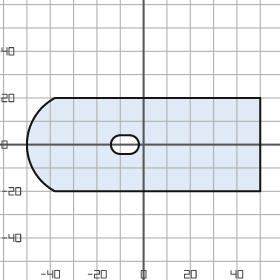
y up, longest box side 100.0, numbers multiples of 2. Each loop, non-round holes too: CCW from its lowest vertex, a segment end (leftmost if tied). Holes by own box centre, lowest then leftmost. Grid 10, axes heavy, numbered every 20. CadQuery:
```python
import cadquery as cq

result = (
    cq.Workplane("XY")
    .moveTo(-38.0, -20.0)
    .lineTo(50.0, -20.0)
    .lineTo(50.0, 20.0)
    .lineTo(-38.0, 20.0)
    .threePointArc((-50.0, 0.0), (-38.0, -20.0))
    .close()
    .moveTo(-10.0, -4.0)
    .lineTo(-6.0, -4.0)
    .threePointArc((-2.0, 0.0), (-6.0, 4.0))
    .lineTo(-10.0, 4.0)
    .threePointArc((-14.0, 0.0), (-10.0, -4.0))
    .close()
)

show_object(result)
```